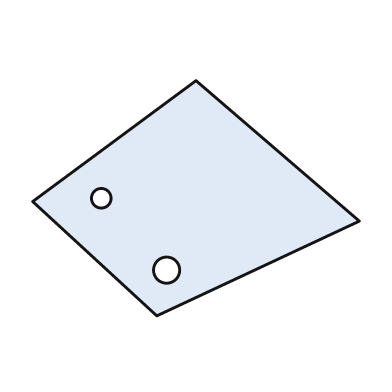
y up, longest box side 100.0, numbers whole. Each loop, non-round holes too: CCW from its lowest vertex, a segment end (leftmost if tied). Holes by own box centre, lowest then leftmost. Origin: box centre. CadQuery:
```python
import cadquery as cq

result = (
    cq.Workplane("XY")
    .moveTo(-12.0, -36.0)
    .lineTo(50.0, -7.0)
    .lineTo(0.0, 36.0)
    .lineTo(-50.0, -1.0)
    .close()
    .moveTo(-9.0, -22.0)
    .circle(4.0)
    .moveTo(-29.0, 0.0)
    .circle(3.0)
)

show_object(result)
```